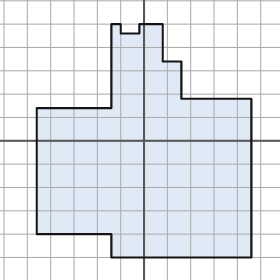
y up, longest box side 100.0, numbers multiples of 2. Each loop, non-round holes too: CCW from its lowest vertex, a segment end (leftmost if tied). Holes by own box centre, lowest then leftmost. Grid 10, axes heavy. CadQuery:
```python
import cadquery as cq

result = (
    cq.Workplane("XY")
    .moveTo(-14.0, -50.0)
    .lineTo(46.0, -50.0)
    .lineTo(46.0, 18.0)
    .lineTo(16.0, 18.0)
    .lineTo(16.0, 34.0)
    .lineTo(8.0, 34.0)
    .lineTo(8.0, 50.0)
    .lineTo(-2.0, 50.0)
    .lineTo(-2.0, 46.0)
    .lineTo(-10.0, 46.0)
    .lineTo(-10.0, 50.0)
    .lineTo(-14.0, 50.0)
    .lineTo(-14.0, 14.0)
    .lineTo(-46.0, 14.0)
    .lineTo(-46.0, -40.0)
    .lineTo(-14.0, -40.0)
    .close()
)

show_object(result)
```